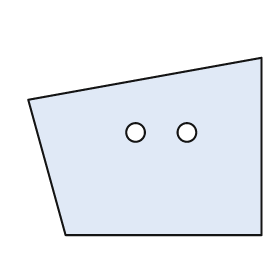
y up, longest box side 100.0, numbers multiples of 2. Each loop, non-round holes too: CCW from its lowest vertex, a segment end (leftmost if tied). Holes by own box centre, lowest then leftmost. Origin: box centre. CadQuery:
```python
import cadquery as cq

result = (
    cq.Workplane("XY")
    .moveTo(-34.0, -38.0)
    .lineTo(50.0, -38.0)
    .lineTo(50.0, 38.0)
    .lineTo(-50.0, 20.0)
    .close()
    .moveTo(-4.0, 6.0)
    .circle(4.0)
    .moveTo(18.0, 6.0)
    .circle(4.0)
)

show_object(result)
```